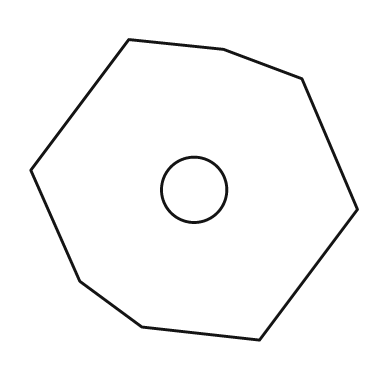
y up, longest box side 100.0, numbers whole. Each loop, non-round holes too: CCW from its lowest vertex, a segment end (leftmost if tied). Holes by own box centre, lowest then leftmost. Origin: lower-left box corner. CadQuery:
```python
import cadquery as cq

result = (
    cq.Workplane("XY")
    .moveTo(70.0, 0.0)
    .lineTo(100.0, 40.0)
    .lineTo(83.0, 80.0)
    .lineTo(59.0, 89.0)
    .lineTo(30.0, 92.0)
    .lineTo(0.0, 52.0)
    .lineTo(15.0, 18.0)
    .lineTo(34.0, 4.0)
    .close()
    .moveTo(50.0, 46.0)
    .circle(10.0)
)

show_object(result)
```